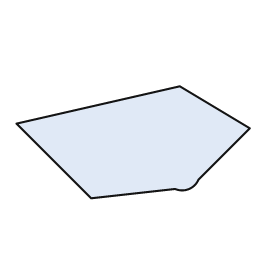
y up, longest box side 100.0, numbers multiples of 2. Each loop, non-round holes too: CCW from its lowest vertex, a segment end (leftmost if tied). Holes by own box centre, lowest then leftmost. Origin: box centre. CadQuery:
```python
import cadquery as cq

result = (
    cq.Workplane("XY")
    .moveTo(-18.0, -24.0)
    .lineTo(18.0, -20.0)
    .threePointArc((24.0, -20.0), (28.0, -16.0))
    .lineTo(50.0, 6.0)
    .lineTo(20.0, 24.0)
    .lineTo(-50.0, 8.0)
    .close()
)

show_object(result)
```